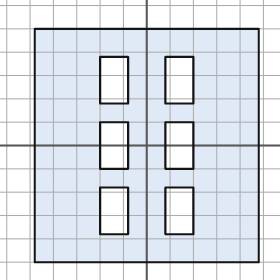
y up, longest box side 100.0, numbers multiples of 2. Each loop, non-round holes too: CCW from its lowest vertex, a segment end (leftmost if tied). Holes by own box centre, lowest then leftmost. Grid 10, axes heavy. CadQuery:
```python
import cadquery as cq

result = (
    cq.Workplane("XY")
    .moveTo(-48.0, -50.0)
    .lineTo(48.0, -50.0)
    .lineTo(48.0, 50.0)
    .lineTo(-48.0, 50.0)
    .close()
    .moveTo(-20.0, -38.0)
    .lineTo(-8.0, -38.0)
    .lineTo(-8.0, -18.0)
    .lineTo(-20.0, -18.0)
    .close()
    .moveTo(8.0, -38.0)
    .lineTo(20.0, -38.0)
    .lineTo(20.0, -18.0)
    .lineTo(8.0, -18.0)
    .close()
    .moveTo(-20.0, -10.0)
    .lineTo(-8.0, -10.0)
    .lineTo(-8.0, 10.0)
    .lineTo(-20.0, 10.0)
    .close()
    .moveTo(8.0, -10.0)
    .lineTo(20.0, -10.0)
    .lineTo(20.0, 10.0)
    .lineTo(8.0, 10.0)
    .close()
    .moveTo(-20.0, 18.0)
    .lineTo(-8.0, 18.0)
    .lineTo(-8.0, 38.0)
    .lineTo(-20.0, 38.0)
    .close()
    .moveTo(8.0, 18.0)
    .lineTo(20.0, 18.0)
    .lineTo(20.0, 38.0)
    .lineTo(8.0, 38.0)
    .close()
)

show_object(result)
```